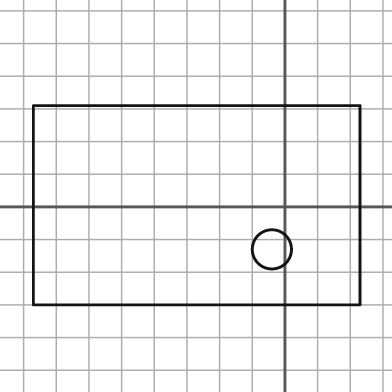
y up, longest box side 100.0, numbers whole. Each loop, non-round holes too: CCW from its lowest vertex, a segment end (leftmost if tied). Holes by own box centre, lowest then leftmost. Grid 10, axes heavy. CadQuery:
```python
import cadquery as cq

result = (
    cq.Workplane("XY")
    .moveTo(-77.0, -30.0)
    .lineTo(23.0, -30.0)
    .lineTo(23.0, 31.0)
    .lineTo(-77.0, 31.0)
    .close()
    .moveTo(-4.0, -13.0)
    .circle(6.0)
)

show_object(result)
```